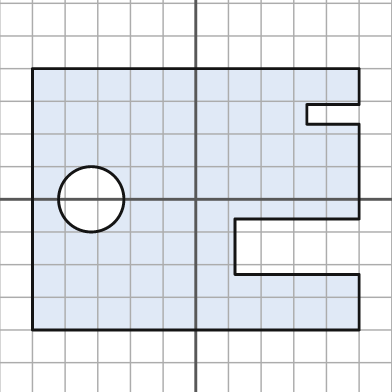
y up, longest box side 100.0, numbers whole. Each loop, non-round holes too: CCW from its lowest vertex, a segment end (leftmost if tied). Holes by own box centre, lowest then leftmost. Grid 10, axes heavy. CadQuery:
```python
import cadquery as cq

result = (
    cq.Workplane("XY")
    .moveTo(-50.0, -40.0)
    .lineTo(50.0, -40.0)
    .lineTo(50.0, -23.0)
    .lineTo(12.0, -23.0)
    .lineTo(12.0, -6.0)
    .lineTo(50.0, -6.0)
    .lineTo(50.0, 23.0)
    .lineTo(34.0, 23.0)
    .lineTo(34.0, 29.0)
    .lineTo(50.0, 29.0)
    .lineTo(50.0, 40.0)
    .lineTo(-50.0, 40.0)
    .close()
    .moveTo(-32.0, 0.0)
    .circle(10.0)
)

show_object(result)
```